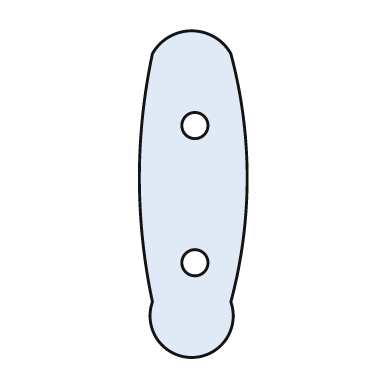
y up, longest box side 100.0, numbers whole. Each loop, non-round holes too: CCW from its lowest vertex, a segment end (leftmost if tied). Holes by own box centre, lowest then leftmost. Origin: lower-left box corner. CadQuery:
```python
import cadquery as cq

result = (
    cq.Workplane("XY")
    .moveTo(4.0, 17.0)
    .threePointArc((16.0, 0.0), (28.0, 17.0))
    .threePointArc((33.0, 55.0), (28.0, 93.0))
    .threePointArc((16.0, 100.0), (4.0, 93.0))
    .threePointArc((0.0, 55.0), (4.0, 17.0))
    .close()
    .moveTo(17.0, 29.0)
    .circle(4.0)
    .moveTo(17.0, 71.0)
    .circle(4.0)
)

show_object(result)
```